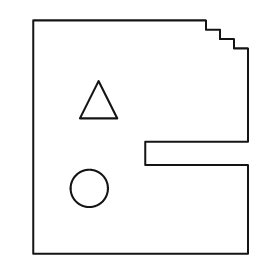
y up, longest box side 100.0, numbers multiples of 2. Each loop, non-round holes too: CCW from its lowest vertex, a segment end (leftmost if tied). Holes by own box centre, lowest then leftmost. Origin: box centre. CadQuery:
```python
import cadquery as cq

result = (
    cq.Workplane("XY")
    .moveTo(-46.0, -50.0)
    .lineTo(46.0, -50.0)
    .lineTo(46.0, -12.0)
    .lineTo(2.0, -12.0)
    .lineTo(2.0, -2.0)
    .lineTo(46.0, -2.0)
    .lineTo(46.0, 38.0)
    .lineTo(40.0, 38.0)
    .lineTo(40.0, 42.0)
    .lineTo(34.0, 42.0)
    .lineTo(34.0, 46.0)
    .lineTo(28.0, 46.0)
    .lineTo(28.0, 50.0)
    .lineTo(-46.0, 50.0)
    .close()
    .moveTo(-22.0, -22.0)
    .circle(8.0)
    .moveTo(-26.0, 8.0)
    .lineTo(-10.0, 8.0)
    .lineTo(-18.0, 24.0)
    .close()
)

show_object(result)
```